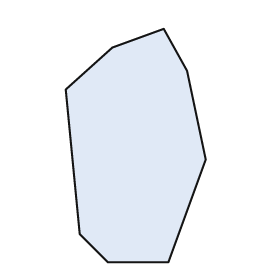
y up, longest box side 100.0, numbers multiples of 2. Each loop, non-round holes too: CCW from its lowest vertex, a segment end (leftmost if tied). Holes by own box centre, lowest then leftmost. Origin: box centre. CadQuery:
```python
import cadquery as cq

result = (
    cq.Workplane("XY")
    .moveTo(-12.0, -50.0)
    .lineTo(14.0, -50.0)
    .lineTo(30.0, -6.0)
    .lineTo(22.0, 32.0)
    .lineTo(12.0, 50.0)
    .lineTo(-10.0, 42.0)
    .lineTo(-30.0, 24.0)
    .lineTo(-24.0, -38.0)
    .close()
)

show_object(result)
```